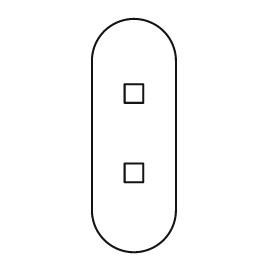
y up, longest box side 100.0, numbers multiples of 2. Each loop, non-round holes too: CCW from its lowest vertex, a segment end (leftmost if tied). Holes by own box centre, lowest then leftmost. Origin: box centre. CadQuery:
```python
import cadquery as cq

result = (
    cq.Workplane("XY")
    .moveTo(-18.0, -32.0)
    .threePointArc((0.0, -50.0), (18.0, -32.0))
    .lineTo(18.0, 32.0)
    .threePointArc((0.0, 50.0), (-18.0, 32.0))
    .close()
    .moveTo(-4.0, -20.0)
    .lineTo(4.0, -20.0)
    .lineTo(4.0, -12.0)
    .lineTo(-4.0, -12.0)
    .close()
    .moveTo(-4.0, 14.0)
    .lineTo(4.0, 14.0)
    .lineTo(4.0, 22.0)
    .lineTo(-4.0, 22.0)
    .close()
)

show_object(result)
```